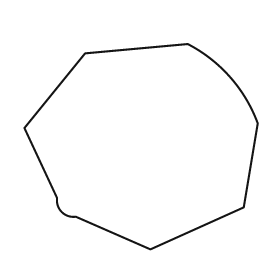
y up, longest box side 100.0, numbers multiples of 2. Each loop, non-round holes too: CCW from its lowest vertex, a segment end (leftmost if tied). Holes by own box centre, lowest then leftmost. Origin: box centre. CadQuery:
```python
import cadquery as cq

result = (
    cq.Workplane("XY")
    .moveTo(4.0, -44.0)
    .lineTo(44.0, -26.0)
    .lineTo(50.0, 10.0)
    .threePointArc((38.0, 30.0), (20.0, 44.0))
    .lineTo(-24.0, 40.0)
    .lineTo(-50.0, 8.0)
    .lineTo(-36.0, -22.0)
    .threePointArc((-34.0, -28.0), (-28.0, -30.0))
    .close()
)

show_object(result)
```